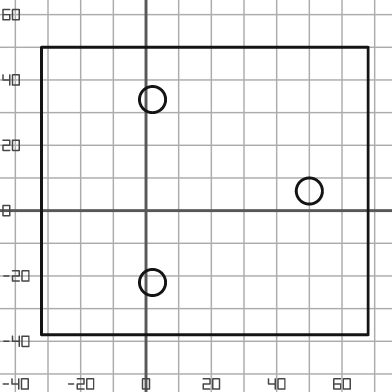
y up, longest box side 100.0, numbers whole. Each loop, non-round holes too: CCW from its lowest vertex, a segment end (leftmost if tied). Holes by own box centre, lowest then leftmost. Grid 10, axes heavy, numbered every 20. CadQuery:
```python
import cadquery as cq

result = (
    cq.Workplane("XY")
    .moveTo(-32.0, -38.0)
    .lineTo(68.0, -38.0)
    .lineTo(68.0, 50.0)
    .lineTo(-32.0, 50.0)
    .close()
    .moveTo(2.0, -22.0)
    .circle(4.0)
    .moveTo(50.0, 6.0)
    .circle(4.0)
    .moveTo(2.0, 34.0)
    .circle(4.0)
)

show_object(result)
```